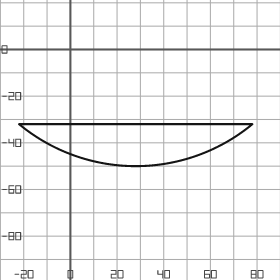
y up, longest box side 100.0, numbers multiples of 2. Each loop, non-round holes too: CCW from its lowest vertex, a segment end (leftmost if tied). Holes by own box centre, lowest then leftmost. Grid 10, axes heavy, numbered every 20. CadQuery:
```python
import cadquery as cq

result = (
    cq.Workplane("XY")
    .moveTo(-22.0, -32.0)
    .threePointArc((28.0, -50.0), (78.0, -32.0))
    .close()
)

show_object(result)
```